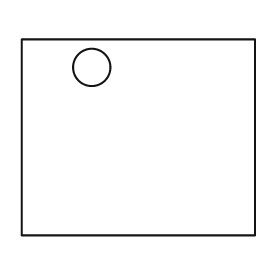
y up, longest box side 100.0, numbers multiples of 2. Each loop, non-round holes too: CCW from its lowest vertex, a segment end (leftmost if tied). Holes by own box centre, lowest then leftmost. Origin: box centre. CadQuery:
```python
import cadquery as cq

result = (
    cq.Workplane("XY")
    .moveTo(-50.0, -42.0)
    .lineTo(50.0, -42.0)
    .lineTo(50.0, 42.0)
    .lineTo(-50.0, 42.0)
    .close()
    .moveTo(-20.0, 30.0)
    .circle(8.0)
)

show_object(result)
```